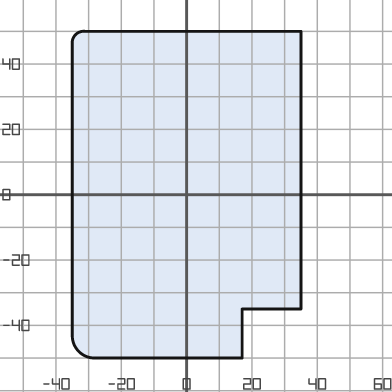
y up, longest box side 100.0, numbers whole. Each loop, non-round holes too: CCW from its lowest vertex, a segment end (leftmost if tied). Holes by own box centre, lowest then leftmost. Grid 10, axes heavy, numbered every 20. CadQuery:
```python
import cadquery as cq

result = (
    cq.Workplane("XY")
    .moveTo(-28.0, -50.0)
    .lineTo(17.0, -50.0)
    .lineTo(17.0, -35.0)
    .lineTo(35.0, -35.0)
    .lineTo(35.0, 50.0)
    .lineTo(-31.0, 50.0)
    .threePointArc((-34.0, 49.0), (-35.0, 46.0))
    .lineTo(-35.0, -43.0)
    .threePointArc((-33.0, -48.0), (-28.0, -50.0))
    .close()
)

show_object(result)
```